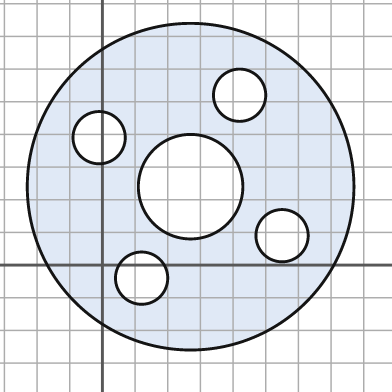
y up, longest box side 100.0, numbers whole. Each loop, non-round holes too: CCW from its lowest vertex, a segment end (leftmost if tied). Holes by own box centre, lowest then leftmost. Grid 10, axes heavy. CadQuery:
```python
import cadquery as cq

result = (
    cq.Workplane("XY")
    .moveTo(27.0, 24.0)
    .circle(50.0)
    .moveTo(12.0, -4.0)
    .circle(8.0)
    .moveTo(55.0, 9.0)
    .circle(8.0)
    .moveTo(27.0, 24.0)
    .circle(16.0)
    .moveTo(-1.0, 39.0)
    .circle(8.0)
    .moveTo(42.0, 52.0)
    .circle(8.0)
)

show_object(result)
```